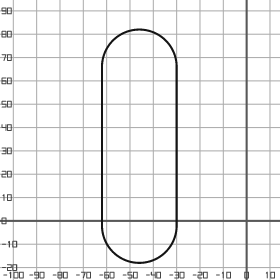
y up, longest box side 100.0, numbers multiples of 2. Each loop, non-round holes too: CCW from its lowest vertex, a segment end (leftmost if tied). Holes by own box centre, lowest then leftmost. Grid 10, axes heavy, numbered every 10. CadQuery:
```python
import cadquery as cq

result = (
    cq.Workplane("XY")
    .moveTo(-62.0, -2.0)
    .threePointArc((-46.0, -18.0), (-30.0, -2.0))
    .lineTo(-30.0, 66.0)
    .threePointArc((-46.0, 82.0), (-62.0, 66.0))
    .close()
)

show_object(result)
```